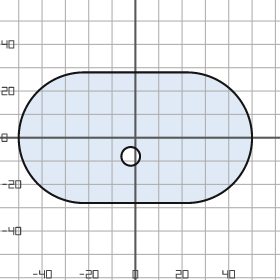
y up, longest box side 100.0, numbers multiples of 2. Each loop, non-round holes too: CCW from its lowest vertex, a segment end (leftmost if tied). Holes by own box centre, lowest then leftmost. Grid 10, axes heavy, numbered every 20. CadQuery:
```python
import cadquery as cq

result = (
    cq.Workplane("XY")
    .moveTo(-22.0, -28.0)
    .lineTo(22.0, -28.0)
    .threePointArc((50.0, 0.0), (22.0, 28.0))
    .lineTo(-22.0, 28.0)
    .threePointArc((-50.0, 0.0), (-22.0, -28.0))
    .close()
    .moveTo(-2.0, -8.0)
    .circle(4.0)
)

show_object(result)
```